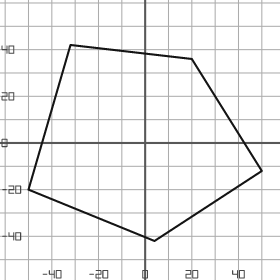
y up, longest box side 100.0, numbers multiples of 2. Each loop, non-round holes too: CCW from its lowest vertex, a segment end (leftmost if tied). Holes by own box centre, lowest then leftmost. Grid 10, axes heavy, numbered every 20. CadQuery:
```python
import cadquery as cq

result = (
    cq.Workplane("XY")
    .moveTo(4.0, -42.0)
    .lineTo(50.0, -12.0)
    .lineTo(20.0, 36.0)
    .lineTo(-32.0, 42.0)
    .lineTo(-50.0, -20.0)
    .close()
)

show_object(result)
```